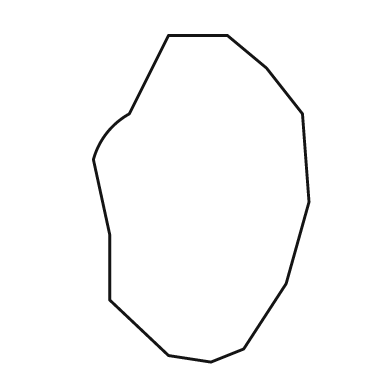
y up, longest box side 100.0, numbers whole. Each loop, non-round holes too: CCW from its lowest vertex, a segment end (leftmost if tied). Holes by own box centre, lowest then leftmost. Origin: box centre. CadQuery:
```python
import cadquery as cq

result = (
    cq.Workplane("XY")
    .moveTo(3.0, -50.0)
    .lineTo(13.0, -46.0)
    .lineTo(26.0, -26.0)
    .lineTo(33.0, -1.0)
    .lineTo(31.0, 26.0)
    .lineTo(20.0, 40.0)
    .lineTo(8.0, 50.0)
    .lineTo(-10.0, 50.0)
    .lineTo(-22.0, 26.0)
    .threePointArc((-29.0, 20.0), (-33.0, 12.0))
    .lineTo(-28.0, -11.0)
    .lineTo(-28.0, -31.0)
    .lineTo(-10.0, -48.0)
    .close()
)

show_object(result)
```